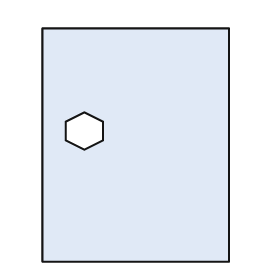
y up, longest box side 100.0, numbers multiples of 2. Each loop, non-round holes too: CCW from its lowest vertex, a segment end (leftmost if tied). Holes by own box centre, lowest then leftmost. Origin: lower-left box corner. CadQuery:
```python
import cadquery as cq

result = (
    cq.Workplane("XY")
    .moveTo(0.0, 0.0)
    .lineTo(80.0, 0.0)
    .lineTo(80.0, 100.0)
    .lineTo(0.0, 100.0)
    .close()
    .moveTo(18.0, 48.0)
    .lineTo(26.0, 52.0)
    .lineTo(26.0, 60.0)
    .lineTo(18.0, 64.0)
    .lineTo(10.0, 60.0)
    .lineTo(10.0, 52.0)
    .close()
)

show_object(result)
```